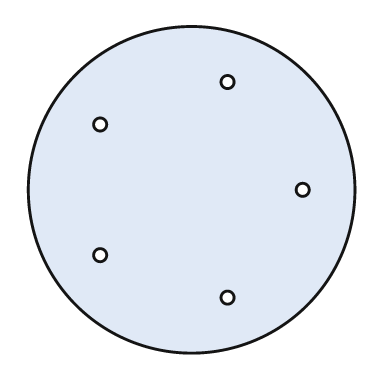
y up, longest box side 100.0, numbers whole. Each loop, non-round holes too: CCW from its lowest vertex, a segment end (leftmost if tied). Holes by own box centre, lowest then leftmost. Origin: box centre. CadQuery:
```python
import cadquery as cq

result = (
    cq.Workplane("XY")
    .moveTo(0.0, 0.0)
    .circle(50.0)
    .moveTo(11.0, -33.0)
    .circle(2.0)
    .moveTo(-28.0, -20.0)
    .circle(2.0)
    .moveTo(34.0, 0.0)
    .circle(2.0)
    .moveTo(-28.0, 20.0)
    .circle(2.0)
    .moveTo(11.0, 33.0)
    .circle(2.0)
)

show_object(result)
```